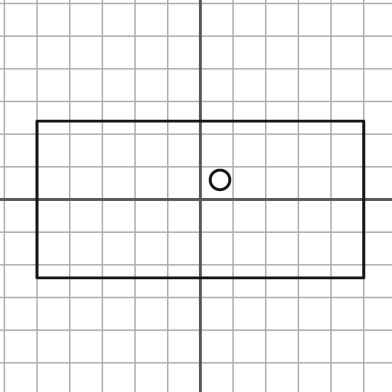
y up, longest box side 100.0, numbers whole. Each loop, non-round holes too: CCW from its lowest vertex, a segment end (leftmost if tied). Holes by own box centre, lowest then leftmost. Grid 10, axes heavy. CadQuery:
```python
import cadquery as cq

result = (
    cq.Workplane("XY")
    .moveTo(-50.0, -24.0)
    .lineTo(50.0, -24.0)
    .lineTo(50.0, 24.0)
    .lineTo(-50.0, 24.0)
    .close()
    .moveTo(6.0, 6.0)
    .circle(3.0)
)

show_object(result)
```